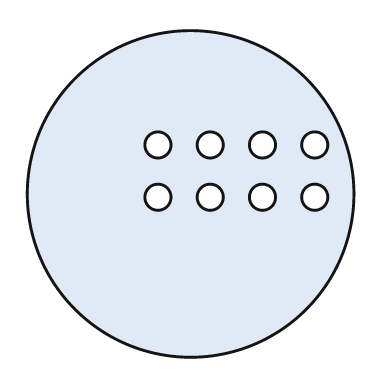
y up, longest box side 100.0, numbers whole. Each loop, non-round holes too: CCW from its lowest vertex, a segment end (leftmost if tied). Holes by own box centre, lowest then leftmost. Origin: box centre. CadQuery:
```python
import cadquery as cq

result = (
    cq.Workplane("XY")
    .moveTo(0.0, 0.0)
    .circle(50.0)
    .moveTo(-10.0, -1.0)
    .circle(4.0)
    .moveTo(6.0, -1.0)
    .circle(4.0)
    .moveTo(22.0, -1.0)
    .circle(4.0)
    .moveTo(38.0, -1.0)
    .circle(4.0)
    .moveTo(-10.0, 15.0)
    .circle(4.0)
    .moveTo(6.0, 15.0)
    .circle(4.0)
    .moveTo(22.0, 15.0)
    .circle(4.0)
    .moveTo(38.0, 15.0)
    .circle(4.0)
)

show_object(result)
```